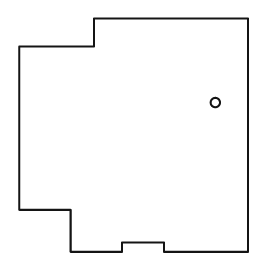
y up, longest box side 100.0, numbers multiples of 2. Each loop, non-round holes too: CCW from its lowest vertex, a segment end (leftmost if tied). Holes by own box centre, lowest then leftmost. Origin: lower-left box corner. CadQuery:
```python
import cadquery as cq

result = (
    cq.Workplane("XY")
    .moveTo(22.0, 0.0)
    .lineTo(44.0, 0.0)
    .lineTo(44.0, 4.0)
    .lineTo(62.0, 4.0)
    .lineTo(62.0, 0.0)
    .lineTo(98.0, 0.0)
    .lineTo(98.0, 100.0)
    .lineTo(32.0, 100.0)
    .lineTo(32.0, 88.0)
    .lineTo(0.0, 88.0)
    .lineTo(0.0, 18.0)
    .lineTo(22.0, 18.0)
    .close()
    .moveTo(84.0, 64.0)
    .circle(2.0)
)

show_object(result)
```